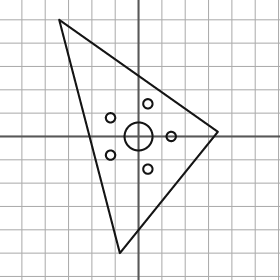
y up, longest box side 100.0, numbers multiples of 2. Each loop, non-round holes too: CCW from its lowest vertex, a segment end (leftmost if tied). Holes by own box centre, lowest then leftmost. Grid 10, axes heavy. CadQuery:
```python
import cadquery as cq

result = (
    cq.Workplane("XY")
    .moveTo(-8.0, -50.0)
    .lineTo(34.0, 2.0)
    .lineTo(-34.0, 50.0)
    .close()
    .moveTo(4.0, -14.0)
    .circle(2.0)
    .moveTo(-12.0, -8.0)
    .circle(2.0)
    .moveTo(0.0, 0.0)
    .circle(6.0)
    .moveTo(14.0, 0.0)
    .circle(2.0)
    .moveTo(-12.0, 8.0)
    .circle(2.0)
    .moveTo(4.0, 14.0)
    .circle(2.0)
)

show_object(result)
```